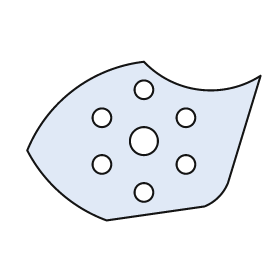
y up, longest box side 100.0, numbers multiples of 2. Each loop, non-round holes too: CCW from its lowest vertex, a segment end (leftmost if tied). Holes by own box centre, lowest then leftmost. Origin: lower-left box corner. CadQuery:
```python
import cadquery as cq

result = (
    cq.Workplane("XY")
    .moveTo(34.0, 0.0)
    .lineTo(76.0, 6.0)
    .threePointArc((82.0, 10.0), (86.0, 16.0))
    .lineTo(100.0, 62.0)
    .threePointArc((74.0, 56.0), (50.0, 68.0))
    .threePointArc((20.0, 56.0), (0.0, 30.0))
    .threePointArc((14.0, 12.0), (34.0, 0.0))
    .close()
    .moveTo(50.0, 12.0)
    .circle(4.0)
    .moveTo(32.0, 24.0)
    .circle(4.0)
    .moveTo(68.0, 24.0)
    .circle(4.0)
    .moveTo(50.0, 34.0)
    .circle(6.0)
    .moveTo(32.0, 44.0)
    .circle(4.0)
    .moveTo(68.0, 44.0)
    .circle(4.0)
    .moveTo(50.0, 56.0)
    .circle(4.0)
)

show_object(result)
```